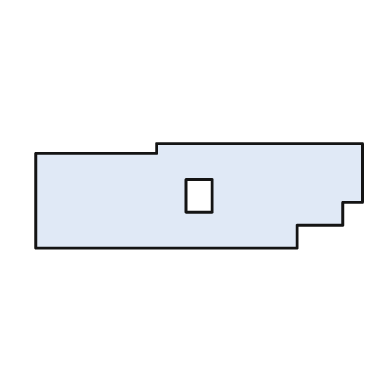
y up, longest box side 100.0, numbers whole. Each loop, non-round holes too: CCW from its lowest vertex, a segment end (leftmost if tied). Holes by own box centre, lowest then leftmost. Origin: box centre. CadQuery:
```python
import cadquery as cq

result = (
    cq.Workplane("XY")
    .moveTo(-50.0, -16.0)
    .lineTo(30.0, -16.0)
    .lineTo(30.0, -9.0)
    .lineTo(44.0, -9.0)
    .lineTo(44.0, -2.0)
    .lineTo(50.0, -2.0)
    .lineTo(50.0, 16.0)
    .lineTo(-13.0, 16.0)
    .lineTo(-13.0, 13.0)
    .lineTo(-50.0, 13.0)
    .close()
    .moveTo(-4.0, -5.0)
    .lineTo(4.0, -5.0)
    .lineTo(4.0, 5.0)
    .lineTo(-4.0, 5.0)
    .close()
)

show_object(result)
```